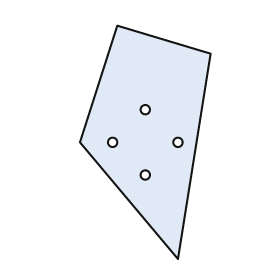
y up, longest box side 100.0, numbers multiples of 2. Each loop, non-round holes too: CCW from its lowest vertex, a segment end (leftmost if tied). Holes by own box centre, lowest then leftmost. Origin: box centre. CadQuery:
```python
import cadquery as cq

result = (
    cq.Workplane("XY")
    .moveTo(14.0, -50.0)
    .lineTo(28.0, 38.0)
    .lineTo(-12.0, 50.0)
    .lineTo(-28.0, 0.0)
    .close()
    .moveTo(0.0, -14.0)
    .circle(2.0)
    .moveTo(-14.0, 0.0)
    .circle(2.0)
    .moveTo(14.0, 0.0)
    .circle(2.0)
    .moveTo(0.0, 14.0)
    .circle(2.0)
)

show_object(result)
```